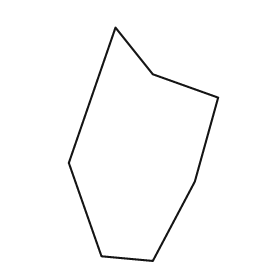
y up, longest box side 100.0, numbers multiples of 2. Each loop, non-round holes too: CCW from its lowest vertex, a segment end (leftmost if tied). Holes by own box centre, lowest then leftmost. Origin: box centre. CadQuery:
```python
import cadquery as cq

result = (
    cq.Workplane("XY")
    .moveTo(4.0, -50.0)
    .lineTo(22.0, -16.0)
    .lineTo(32.0, 20.0)
    .lineTo(4.0, 30.0)
    .lineTo(-12.0, 50.0)
    .lineTo(-32.0, -8.0)
    .lineTo(-18.0, -48.0)
    .close()
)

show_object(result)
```